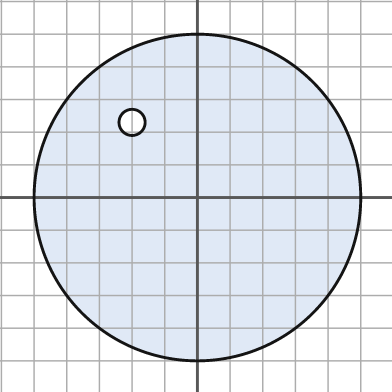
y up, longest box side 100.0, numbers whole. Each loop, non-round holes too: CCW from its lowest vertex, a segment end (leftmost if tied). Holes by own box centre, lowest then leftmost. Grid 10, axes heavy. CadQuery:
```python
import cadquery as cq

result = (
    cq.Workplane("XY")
    .moveTo(0.0, 0.0)
    .circle(50.0)
    .moveTo(-20.0, 23.0)
    .circle(4.0)
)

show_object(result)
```